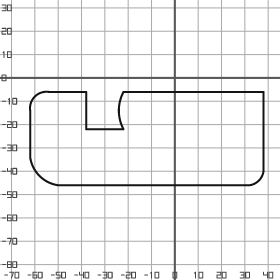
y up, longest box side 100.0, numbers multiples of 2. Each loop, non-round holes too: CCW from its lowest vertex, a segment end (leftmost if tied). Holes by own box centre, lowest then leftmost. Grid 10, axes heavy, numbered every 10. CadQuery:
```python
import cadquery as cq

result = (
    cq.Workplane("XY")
    .moveTo(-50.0, -46.0)
    .lineTo(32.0, -46.0)
    .threePointArc((36.0, -44.0), (38.0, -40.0))
    .lineTo(38.0, -6.0)
    .lineTo(-22.0, -6.0)
    .threePointArc((-24.0, -14.0), (-22.0, -22.0))
    .lineTo(-38.0, -22.0)
    .lineTo(-38.0, -6.0)
    .lineTo(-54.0, -6.0)
    .threePointArc((-60.0, -8.0), (-62.0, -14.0))
    .lineTo(-62.0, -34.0)
    .threePointArc((-58.0, -42.0), (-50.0, -46.0))
    .close()
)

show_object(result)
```